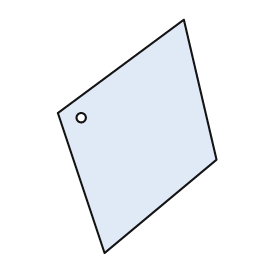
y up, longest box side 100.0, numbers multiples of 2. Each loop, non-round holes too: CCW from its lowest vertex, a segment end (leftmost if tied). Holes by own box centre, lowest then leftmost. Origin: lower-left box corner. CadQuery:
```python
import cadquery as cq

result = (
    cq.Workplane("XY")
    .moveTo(20.0, 0.0)
    .lineTo(68.0, 40.0)
    .lineTo(54.0, 100.0)
    .lineTo(0.0, 60.0)
    .close()
    .moveTo(10.0, 58.0)
    .circle(2.0)
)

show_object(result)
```